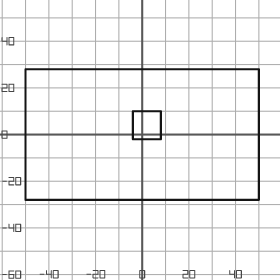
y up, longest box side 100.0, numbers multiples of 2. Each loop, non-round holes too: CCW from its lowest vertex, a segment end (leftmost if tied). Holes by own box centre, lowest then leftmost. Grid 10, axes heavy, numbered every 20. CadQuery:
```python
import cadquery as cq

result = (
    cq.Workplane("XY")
    .moveTo(-50.0, -28.0)
    .lineTo(50.0, -28.0)
    .lineTo(50.0, 28.0)
    .lineTo(-50.0, 28.0)
    .close()
    .moveTo(-4.0, -2.0)
    .lineTo(8.0, -2.0)
    .lineTo(8.0, 10.0)
    .lineTo(-4.0, 10.0)
    .close()
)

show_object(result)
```